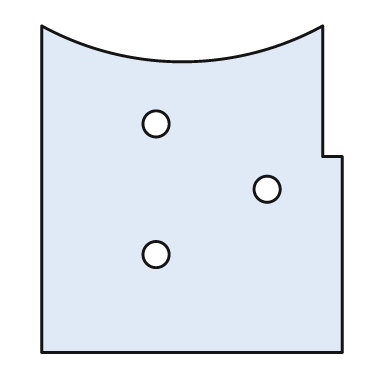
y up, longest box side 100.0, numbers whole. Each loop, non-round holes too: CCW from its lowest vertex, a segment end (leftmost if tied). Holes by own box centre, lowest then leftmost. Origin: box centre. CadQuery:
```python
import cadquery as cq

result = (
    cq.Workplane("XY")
    .moveTo(-46.0, -50.0)
    .lineTo(46.0, -50.0)
    .lineTo(46.0, 10.0)
    .lineTo(40.0, 10.0)
    .lineTo(40.0, 50.0)
    .threePointArc((-3.0, 39.0), (-46.0, 50.0))
    .close()
    .moveTo(-11.0, -20.0)
    .circle(4.0)
    .moveTo(23.0, 0.0)
    .circle(4.0)
    .moveTo(-11.0, 20.0)
    .circle(4.0)
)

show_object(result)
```